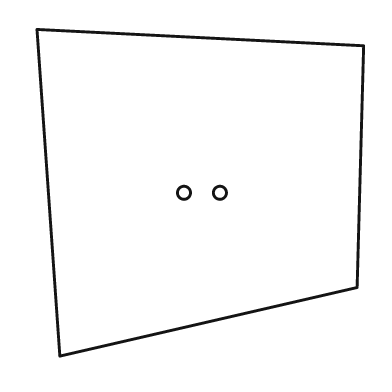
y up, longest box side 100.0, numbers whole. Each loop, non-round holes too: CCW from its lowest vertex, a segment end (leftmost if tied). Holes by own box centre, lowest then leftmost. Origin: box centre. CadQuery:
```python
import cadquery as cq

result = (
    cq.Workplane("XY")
    .moveTo(-43.0, -50.0)
    .lineTo(48.0, -29.0)
    .lineTo(50.0, 45.0)
    .lineTo(-50.0, 50.0)
    .close()
    .moveTo(-5.0, 0.0)
    .circle(2.0)
    .moveTo(6.0, 0.0)
    .circle(2.0)
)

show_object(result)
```